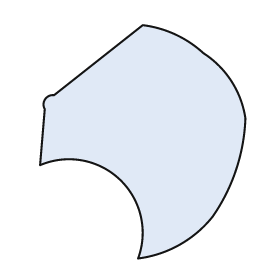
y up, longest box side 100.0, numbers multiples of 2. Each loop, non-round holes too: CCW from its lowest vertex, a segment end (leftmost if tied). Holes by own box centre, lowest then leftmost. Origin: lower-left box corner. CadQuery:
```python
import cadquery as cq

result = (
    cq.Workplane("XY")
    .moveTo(42.0, 0.0)
    .threePointArc((60.0, 6.0), (74.0, 18.0))
    .threePointArc((84.0, 38.0), (88.0, 60.0))
    .threePointArc((82.0, 76.0), (70.0, 88.0))
    .threePointArc((58.0, 96.0), (44.0, 100.0))
    .lineTo(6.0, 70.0)
    .threePointArc((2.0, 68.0), (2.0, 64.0))
    .lineTo(0.0, 40.0)
    .threePointArc((34.0, 34.0), (42.0, 0.0))
    .close()
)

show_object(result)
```